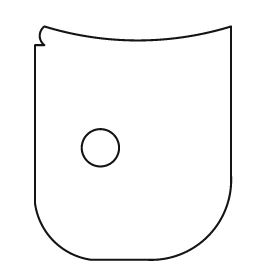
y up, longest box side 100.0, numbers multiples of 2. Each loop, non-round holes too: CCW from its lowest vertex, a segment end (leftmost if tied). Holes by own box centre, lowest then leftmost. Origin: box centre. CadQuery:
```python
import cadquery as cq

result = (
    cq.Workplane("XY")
    .moveTo(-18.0, -50.0)
    .lineTo(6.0, -50.0)
    .threePointArc((32.0, -40.0), (42.0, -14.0))
    .lineTo(42.0, 50.0)
    .threePointArc((2.0, 44.0), (-38.0, 50.0))
    .threePointArc((-40.0, 46.0), (-38.0, 42.0))
    .lineTo(-42.0, 42.0)
    .lineTo(-42.0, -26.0)
    .threePointArc((-34.0, -42.0), (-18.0, -50.0))
    .close()
    .moveTo(-14.0, -2.0)
    .circle(8.0)
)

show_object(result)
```